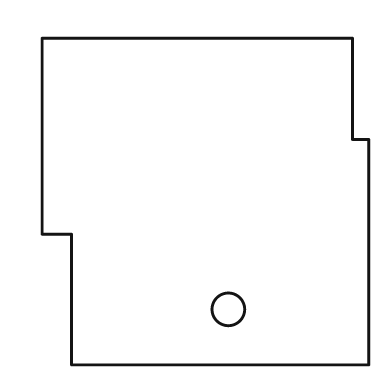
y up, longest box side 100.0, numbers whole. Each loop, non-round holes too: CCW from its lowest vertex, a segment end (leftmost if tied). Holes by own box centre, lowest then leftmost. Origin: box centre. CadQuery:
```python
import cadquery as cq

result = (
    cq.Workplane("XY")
    .moveTo(-41.0, -50.0)
    .lineTo(50.0, -50.0)
    .lineTo(50.0, 19.0)
    .lineTo(45.0, 19.0)
    .lineTo(45.0, 50.0)
    .lineTo(-50.0, 50.0)
    .lineTo(-50.0, -10.0)
    .lineTo(-41.0, -10.0)
    .close()
    .moveTo(7.0, -33.0)
    .circle(5.0)
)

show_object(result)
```